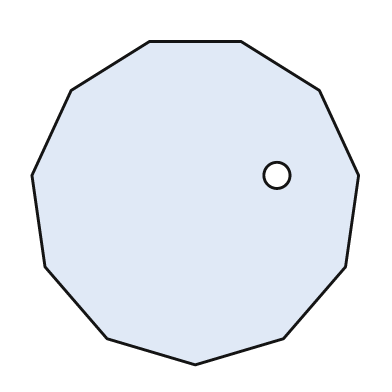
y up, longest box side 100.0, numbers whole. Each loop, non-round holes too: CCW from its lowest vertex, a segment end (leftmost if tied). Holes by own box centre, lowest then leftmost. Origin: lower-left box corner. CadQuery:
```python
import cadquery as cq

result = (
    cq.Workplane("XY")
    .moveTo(50.0, 0.0)
    .lineTo(77.0, 8.0)
    .lineTo(96.0, 30.0)
    .lineTo(100.0, 58.0)
    .lineTo(88.0, 84.0)
    .lineTo(64.0, 99.0)
    .lineTo(36.0, 99.0)
    .lineTo(12.0, 84.0)
    .lineTo(0.0, 58.0)
    .lineTo(4.0, 30.0)
    .lineTo(23.0, 8.0)
    .close()
    .moveTo(75.0, 58.0)
    .circle(4.0)
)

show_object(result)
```